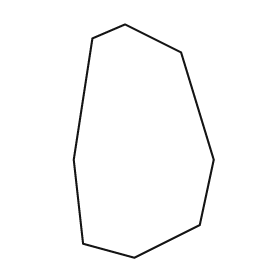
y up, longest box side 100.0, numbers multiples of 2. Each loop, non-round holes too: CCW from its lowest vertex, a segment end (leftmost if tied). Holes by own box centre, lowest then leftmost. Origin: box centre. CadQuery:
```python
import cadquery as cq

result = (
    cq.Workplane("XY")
    .moveTo(-4.0, -50.0)
    .lineTo(24.0, -36.0)
    .lineTo(30.0, -8.0)
    .lineTo(16.0, 38.0)
    .lineTo(-8.0, 50.0)
    .lineTo(-22.0, 44.0)
    .lineTo(-30.0, -8.0)
    .lineTo(-26.0, -44.0)
    .close()
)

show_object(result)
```